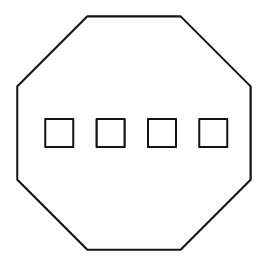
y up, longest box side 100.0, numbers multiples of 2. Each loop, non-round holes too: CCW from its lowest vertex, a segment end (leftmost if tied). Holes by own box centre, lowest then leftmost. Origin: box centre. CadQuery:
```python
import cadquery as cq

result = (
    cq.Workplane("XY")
    .moveTo(-20.0, -50.0)
    .lineTo(20.0, -50.0)
    .lineTo(50.0, -20.0)
    .lineTo(50.0, 20.0)
    .lineTo(20.0, 50.0)
    .lineTo(-20.0, 50.0)
    .lineTo(-50.0, 20.0)
    .lineTo(-50.0, -20.0)
    .close()
    .moveTo(-38.0, -6.0)
    .lineTo(-26.0, -6.0)
    .lineTo(-26.0, 6.0)
    .lineTo(-38.0, 6.0)
    .close()
    .moveTo(-16.0, -6.0)
    .lineTo(-4.0, -6.0)
    .lineTo(-4.0, 6.0)
    .lineTo(-16.0, 6.0)
    .close()
    .moveTo(6.0, -6.0)
    .lineTo(18.0, -6.0)
    .lineTo(18.0, 6.0)
    .lineTo(6.0, 6.0)
    .close()
    .moveTo(28.0, -6.0)
    .lineTo(40.0, -6.0)
    .lineTo(40.0, 6.0)
    .lineTo(28.0, 6.0)
    .close()
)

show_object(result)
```